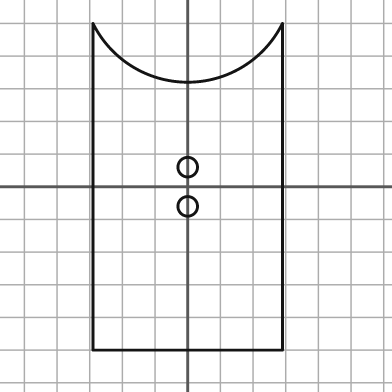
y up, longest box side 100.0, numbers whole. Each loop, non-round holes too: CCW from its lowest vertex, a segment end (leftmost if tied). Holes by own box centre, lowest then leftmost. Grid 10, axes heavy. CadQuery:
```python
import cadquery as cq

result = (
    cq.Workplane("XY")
    .moveTo(-29.0, -50.0)
    .lineTo(29.0, -50.0)
    .lineTo(29.0, 50.0)
    .threePointArc((0.0, 32.0), (-29.0, 50.0))
    .close()
    .moveTo(0.0, -6.0)
    .circle(3.0)
    .moveTo(0.0, 6.0)
    .circle(3.0)
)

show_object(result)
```